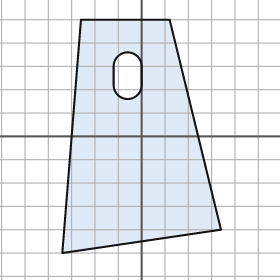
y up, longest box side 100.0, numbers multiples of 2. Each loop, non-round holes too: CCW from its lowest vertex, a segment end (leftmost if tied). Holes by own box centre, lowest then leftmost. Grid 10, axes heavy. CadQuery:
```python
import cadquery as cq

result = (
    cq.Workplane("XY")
    .moveTo(-34.0, -50.0)
    .lineTo(34.0, -40.0)
    .lineTo(12.0, 50.0)
    .lineTo(-26.0, 50.0)
    .close()
    .moveTo(-12.0, 22.0)
    .threePointArc((-6.0, 16.0), (0.0, 22.0))
    .lineTo(0.0, 30.0)
    .threePointArc((-6.0, 36.0), (-12.0, 30.0))
    .close()
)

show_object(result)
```